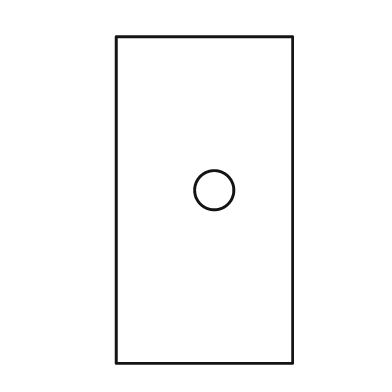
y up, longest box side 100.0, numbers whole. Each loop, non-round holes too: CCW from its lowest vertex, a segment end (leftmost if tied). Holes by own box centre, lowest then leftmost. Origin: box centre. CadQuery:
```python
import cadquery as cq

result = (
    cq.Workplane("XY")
    .moveTo(-27.0, -50.0)
    .lineTo(27.0, -50.0)
    .lineTo(27.0, 50.0)
    .lineTo(-27.0, 50.0)
    .close()
    .moveTo(3.0, 3.0)
    .circle(6.0)
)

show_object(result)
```